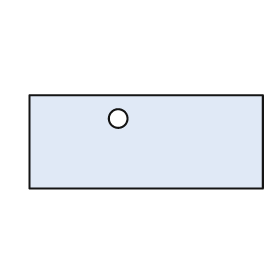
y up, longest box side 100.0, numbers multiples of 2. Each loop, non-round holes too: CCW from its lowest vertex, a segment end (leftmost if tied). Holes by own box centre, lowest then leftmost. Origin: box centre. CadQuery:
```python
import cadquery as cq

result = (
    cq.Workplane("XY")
    .moveTo(-50.0, -20.0)
    .lineTo(50.0, -20.0)
    .lineTo(50.0, 20.0)
    .lineTo(-50.0, 20.0)
    .close()
    .moveTo(-12.0, 10.0)
    .circle(4.0)
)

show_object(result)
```